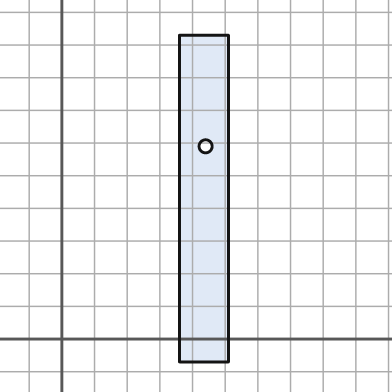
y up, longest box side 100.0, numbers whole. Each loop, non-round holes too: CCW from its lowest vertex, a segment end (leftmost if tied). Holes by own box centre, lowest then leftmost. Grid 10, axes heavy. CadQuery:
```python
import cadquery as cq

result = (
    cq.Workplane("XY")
    .moveTo(36.0, -7.0)
    .lineTo(51.0, -7.0)
    .lineTo(51.0, 93.0)
    .lineTo(36.0, 93.0)
    .close()
    .moveTo(44.0, 59.0)
    .circle(2.0)
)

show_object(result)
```